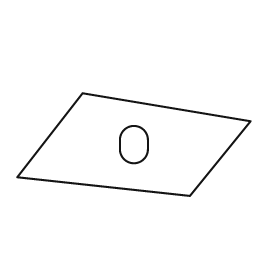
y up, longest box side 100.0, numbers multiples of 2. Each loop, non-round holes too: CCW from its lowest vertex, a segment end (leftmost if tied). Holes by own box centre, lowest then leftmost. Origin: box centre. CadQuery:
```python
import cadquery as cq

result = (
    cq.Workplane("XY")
    .moveTo(24.0, -22.0)
    .lineTo(50.0, 10.0)
    .lineTo(-22.0, 22.0)
    .lineTo(-50.0, -14.0)
    .close()
    .moveTo(-6.0, -2.0)
    .threePointArc((0.0, -8.0), (6.0, -2.0))
    .lineTo(6.0, 2.0)
    .threePointArc((0.0, 8.0), (-6.0, 2.0))
    .close()
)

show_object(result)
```